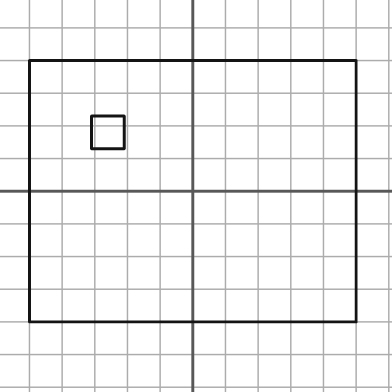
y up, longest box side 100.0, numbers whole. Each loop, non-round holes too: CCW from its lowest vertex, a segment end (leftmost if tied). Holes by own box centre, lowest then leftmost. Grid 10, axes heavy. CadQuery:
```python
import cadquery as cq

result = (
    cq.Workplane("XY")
    .moveTo(-50.0, -40.0)
    .lineTo(50.0, -40.0)
    .lineTo(50.0, 40.0)
    .lineTo(-50.0, 40.0)
    .close()
    .moveTo(-31.0, 13.0)
    .lineTo(-21.0, 13.0)
    .lineTo(-21.0, 23.0)
    .lineTo(-31.0, 23.0)
    .close()
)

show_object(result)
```